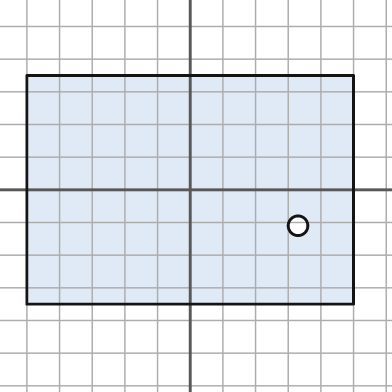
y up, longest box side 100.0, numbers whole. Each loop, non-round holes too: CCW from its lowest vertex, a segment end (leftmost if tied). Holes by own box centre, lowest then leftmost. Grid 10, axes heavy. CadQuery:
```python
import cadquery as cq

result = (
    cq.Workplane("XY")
    .moveTo(-50.0, -35.0)
    .lineTo(50.0, -35.0)
    .lineTo(50.0, 35.0)
    .lineTo(-50.0, 35.0)
    .close()
    .moveTo(33.0, -11.0)
    .circle(3.0)
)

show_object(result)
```